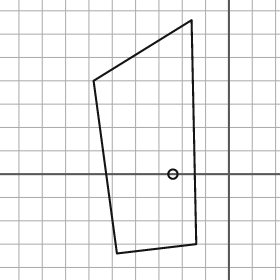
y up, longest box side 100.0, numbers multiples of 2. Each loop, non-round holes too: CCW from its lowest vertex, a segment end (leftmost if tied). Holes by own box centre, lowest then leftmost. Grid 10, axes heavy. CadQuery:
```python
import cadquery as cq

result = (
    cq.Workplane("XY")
    .moveTo(-48.0, -34.0)
    .lineTo(-14.0, -30.0)
    .lineTo(-16.0, 66.0)
    .lineTo(-58.0, 40.0)
    .close()
    .moveTo(-24.0, 0.0)
    .circle(2.0)
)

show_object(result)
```